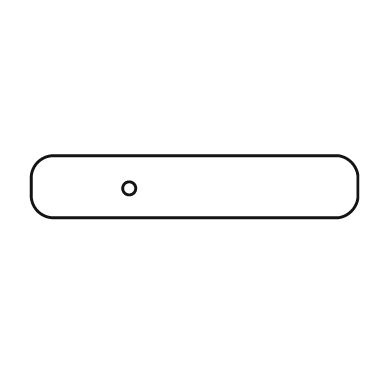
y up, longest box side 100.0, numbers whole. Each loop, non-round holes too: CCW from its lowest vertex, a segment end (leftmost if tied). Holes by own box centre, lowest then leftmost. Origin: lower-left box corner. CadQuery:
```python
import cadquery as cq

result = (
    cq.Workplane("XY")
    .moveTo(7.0, 0.0)
    .lineTo(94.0, 0.0)
    .threePointArc((98.0, 2.0), (100.0, 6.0))
    .lineTo(100.0, 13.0)
    .threePointArc((98.0, 17.0), (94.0, 19.0))
    .lineTo(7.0, 19.0)
    .threePointArc((2.0, 17.0), (0.0, 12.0))
    .lineTo(0.0, 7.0)
    .threePointArc((2.0, 2.0), (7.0, 0.0))
    .close()
    .moveTo(30.0, 9.0)
    .circle(2.0)
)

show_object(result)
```